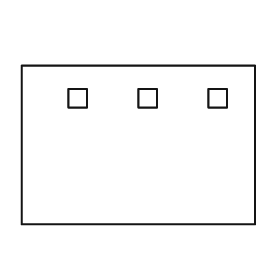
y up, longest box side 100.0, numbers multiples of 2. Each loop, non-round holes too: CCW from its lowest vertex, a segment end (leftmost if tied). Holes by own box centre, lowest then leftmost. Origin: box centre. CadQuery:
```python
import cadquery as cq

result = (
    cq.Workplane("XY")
    .moveTo(-50.0, -34.0)
    .lineTo(50.0, -34.0)
    .lineTo(50.0, 34.0)
    .lineTo(-50.0, 34.0)
    .close()
    .moveTo(-30.0, 16.0)
    .lineTo(-22.0, 16.0)
    .lineTo(-22.0, 24.0)
    .lineTo(-30.0, 24.0)
    .close()
    .moveTo(0.0, 16.0)
    .lineTo(8.0, 16.0)
    .lineTo(8.0, 24.0)
    .lineTo(0.0, 24.0)
    .close()
    .moveTo(30.0, 16.0)
    .lineTo(38.0, 16.0)
    .lineTo(38.0, 24.0)
    .lineTo(30.0, 24.0)
    .close()
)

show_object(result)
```